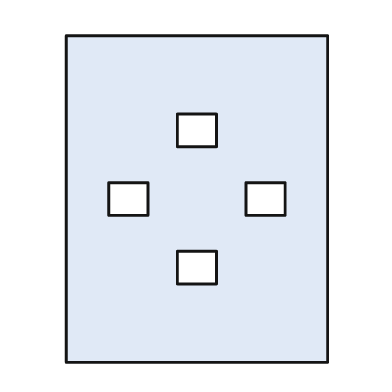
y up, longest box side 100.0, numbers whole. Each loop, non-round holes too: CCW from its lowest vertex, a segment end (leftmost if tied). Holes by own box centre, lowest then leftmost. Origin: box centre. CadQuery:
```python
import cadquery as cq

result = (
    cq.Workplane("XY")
    .moveTo(-40.0, -50.0)
    .lineTo(40.0, -50.0)
    .lineTo(40.0, 50.0)
    .lineTo(-40.0, 50.0)
    .close()
    .moveTo(-6.0, -26.0)
    .lineTo(6.0, -26.0)
    .lineTo(6.0, -16.0)
    .lineTo(-6.0, -16.0)
    .close()
    .moveTo(-27.0, -5.0)
    .lineTo(-15.0, -5.0)
    .lineTo(-15.0, 5.0)
    .lineTo(-27.0, 5.0)
    .close()
    .moveTo(15.0, -5.0)
    .lineTo(27.0, -5.0)
    .lineTo(27.0, 5.0)
    .lineTo(15.0, 5.0)
    .close()
    .moveTo(-6.0, 16.0)
    .lineTo(6.0, 16.0)
    .lineTo(6.0, 26.0)
    .lineTo(-6.0, 26.0)
    .close()
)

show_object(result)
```